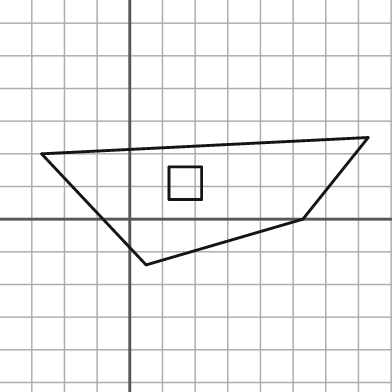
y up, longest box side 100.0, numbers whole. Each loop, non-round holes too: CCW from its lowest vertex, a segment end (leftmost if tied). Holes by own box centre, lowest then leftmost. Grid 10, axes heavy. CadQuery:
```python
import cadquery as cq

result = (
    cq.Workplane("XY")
    .moveTo(5.0, -14.0)
    .lineTo(53.0, 0.0)
    .lineTo(73.0, 25.0)
    .lineTo(-27.0, 20.0)
    .close()
    .moveTo(12.0, 6.0)
    .lineTo(22.0, 6.0)
    .lineTo(22.0, 16.0)
    .lineTo(12.0, 16.0)
    .close()
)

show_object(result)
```